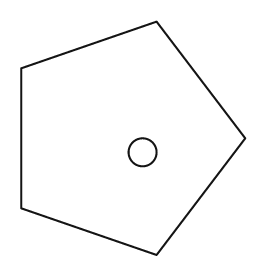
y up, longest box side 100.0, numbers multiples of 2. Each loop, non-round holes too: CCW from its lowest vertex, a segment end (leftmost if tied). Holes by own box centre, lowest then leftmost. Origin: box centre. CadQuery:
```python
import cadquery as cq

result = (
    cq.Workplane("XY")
    .moveTo(10.0, -50.0)
    .lineTo(48.0, 0.0)
    .lineTo(10.0, 50.0)
    .lineTo(-48.0, 30.0)
    .lineTo(-48.0, -30.0)
    .close()
    .moveTo(4.0, -6.0)
    .circle(6.0)
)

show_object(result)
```